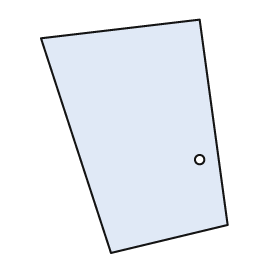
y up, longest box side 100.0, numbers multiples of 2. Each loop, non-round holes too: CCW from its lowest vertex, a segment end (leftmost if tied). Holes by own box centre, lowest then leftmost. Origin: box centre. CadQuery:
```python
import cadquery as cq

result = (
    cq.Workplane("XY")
    .moveTo(-10.0, -50.0)
    .lineTo(40.0, -38.0)
    .lineTo(28.0, 50.0)
    .lineTo(-40.0, 42.0)
    .close()
    .moveTo(28.0, -10.0)
    .circle(2.0)
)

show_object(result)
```